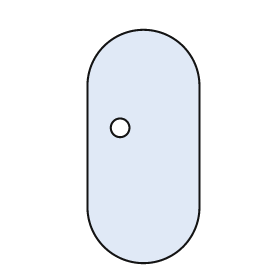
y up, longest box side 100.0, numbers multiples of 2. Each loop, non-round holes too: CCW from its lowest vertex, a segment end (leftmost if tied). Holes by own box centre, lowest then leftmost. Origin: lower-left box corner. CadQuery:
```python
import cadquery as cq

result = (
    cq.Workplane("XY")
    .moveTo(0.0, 24.0)
    .threePointArc((24.0, 0.0), (48.0, 24.0))
    .lineTo(48.0, 76.0)
    .threePointArc((24.0, 100.0), (0.0, 76.0))
    .close()
    .moveTo(14.0, 58.0)
    .circle(4.0)
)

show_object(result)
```